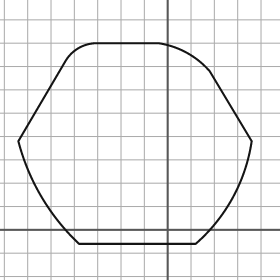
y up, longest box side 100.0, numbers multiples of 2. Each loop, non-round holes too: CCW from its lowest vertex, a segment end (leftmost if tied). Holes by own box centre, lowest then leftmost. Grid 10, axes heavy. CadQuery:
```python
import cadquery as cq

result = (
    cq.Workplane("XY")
    .moveTo(-38.0, -6.0)
    .lineTo(12.0, -6.0)
    .threePointArc((28.0, 14.0), (36.0, 38.0))
    .lineTo(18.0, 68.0)
    .threePointArc((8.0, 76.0), (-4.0, 80.0))
    .lineTo(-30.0, 80.0)
    .threePointArc((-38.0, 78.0), (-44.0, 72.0))
    .lineTo(-64.0, 38.0)
    .threePointArc((-54.0, 14.0), (-38.0, -6.0))
    .close()
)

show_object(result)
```